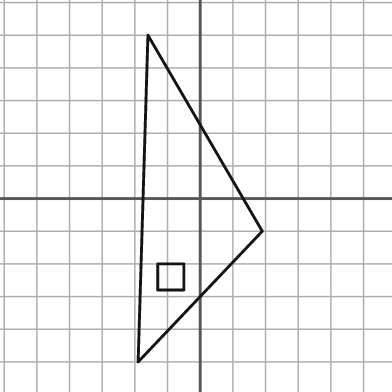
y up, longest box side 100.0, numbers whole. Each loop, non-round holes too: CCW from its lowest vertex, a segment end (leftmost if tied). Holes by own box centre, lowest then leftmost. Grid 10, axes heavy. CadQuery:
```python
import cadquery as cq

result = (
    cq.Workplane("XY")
    .moveTo(-19.0, -50.0)
    .lineTo(19.0, -10.0)
    .lineTo(-16.0, 50.0)
    .close()
    .moveTo(-13.0, -28.0)
    .lineTo(-5.0, -28.0)
    .lineTo(-5.0, -20.0)
    .lineTo(-13.0, -20.0)
    .close()
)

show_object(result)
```